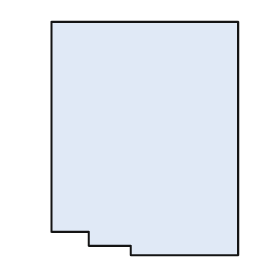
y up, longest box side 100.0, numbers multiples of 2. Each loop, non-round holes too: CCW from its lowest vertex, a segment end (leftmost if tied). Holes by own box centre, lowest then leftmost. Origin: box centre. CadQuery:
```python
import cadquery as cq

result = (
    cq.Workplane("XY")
    .moveTo(-6.0, -50.0)
    .lineTo(40.0, -50.0)
    .lineTo(40.0, 50.0)
    .lineTo(-40.0, 50.0)
    .lineTo(-40.0, -40.0)
    .lineTo(-24.0, -40.0)
    .lineTo(-24.0, -46.0)
    .lineTo(-6.0, -46.0)
    .close()
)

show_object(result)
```